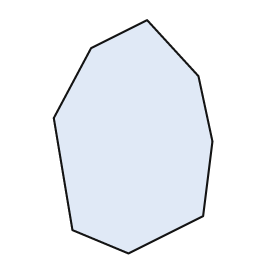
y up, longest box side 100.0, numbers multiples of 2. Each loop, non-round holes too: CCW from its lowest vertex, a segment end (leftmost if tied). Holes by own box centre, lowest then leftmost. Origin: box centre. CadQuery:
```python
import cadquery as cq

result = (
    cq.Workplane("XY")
    .moveTo(-2.0, -50.0)
    .lineTo(30.0, -34.0)
    .lineTo(34.0, -2.0)
    .lineTo(28.0, 26.0)
    .lineTo(6.0, 50.0)
    .lineTo(-18.0, 38.0)
    .lineTo(-34.0, 8.0)
    .lineTo(-26.0, -40.0)
    .close()
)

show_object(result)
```